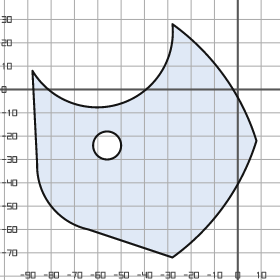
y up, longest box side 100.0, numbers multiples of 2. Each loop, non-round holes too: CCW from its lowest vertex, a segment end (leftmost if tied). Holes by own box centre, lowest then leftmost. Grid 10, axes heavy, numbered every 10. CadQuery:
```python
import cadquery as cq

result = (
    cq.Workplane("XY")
    .moveTo(-28.0, -72.0)
    .threePointArc((-6.0, -50.0), (8.0, -22.0))
    .threePointArc((-6.0, 6.0), (-28.0, 28.0))
    .threePointArc((-50.0, -6.0), (-88.0, 8.0))
    .lineTo(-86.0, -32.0)
    .threePointArc((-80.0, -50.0), (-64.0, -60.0))
    .close()
    .moveTo(-56.0, -24.0)
    .circle(6.0)
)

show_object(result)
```